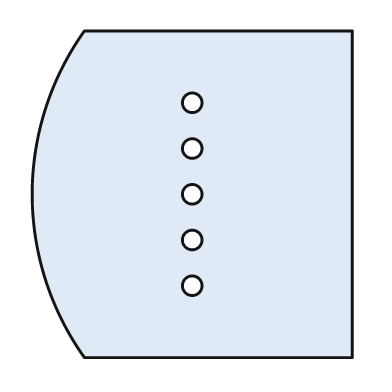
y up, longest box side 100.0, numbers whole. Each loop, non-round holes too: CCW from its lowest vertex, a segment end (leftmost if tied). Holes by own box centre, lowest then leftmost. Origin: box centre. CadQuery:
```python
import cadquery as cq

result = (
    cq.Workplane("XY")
    .moveTo(-33.0, -50.0)
    .lineTo(49.0, -50.0)
    .lineTo(49.0, 50.0)
    .lineTo(-33.0, 50.0)
    .threePointArc((-49.0, 0.0), (-33.0, -50.0))
    .close()
    .moveTo(0.0, -28.0)
    .circle(3.0)
    .moveTo(0.0, -14.0)
    .circle(3.0)
    .moveTo(0.0, 0.0)
    .circle(3.0)
    .moveTo(0.0, 14.0)
    .circle(3.0)
    .moveTo(0.0, 28.0)
    .circle(3.0)
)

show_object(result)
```